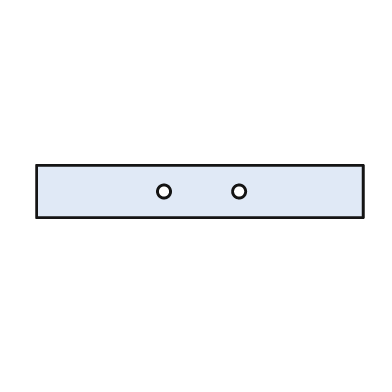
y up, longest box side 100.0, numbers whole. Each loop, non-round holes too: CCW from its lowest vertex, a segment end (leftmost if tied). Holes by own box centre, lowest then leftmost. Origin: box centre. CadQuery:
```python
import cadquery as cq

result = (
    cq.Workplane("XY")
    .moveTo(-50.0, -8.0)
    .lineTo(50.0, -8.0)
    .lineTo(50.0, 8.0)
    .lineTo(-50.0, 8.0)
    .close()
    .moveTo(-11.0, 0.0)
    .circle(2.0)
    .moveTo(12.0, 0.0)
    .circle(2.0)
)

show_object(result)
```